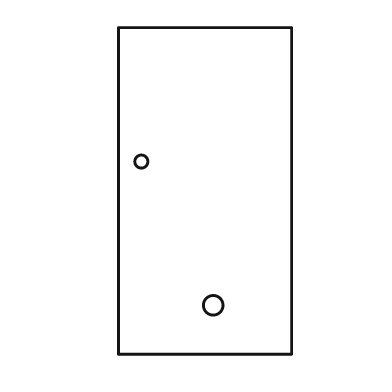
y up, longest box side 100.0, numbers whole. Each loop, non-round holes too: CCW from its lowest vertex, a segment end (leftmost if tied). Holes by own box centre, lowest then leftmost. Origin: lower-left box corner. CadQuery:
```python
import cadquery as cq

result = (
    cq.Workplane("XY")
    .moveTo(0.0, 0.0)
    .lineTo(53.0, 0.0)
    .lineTo(53.0, 100.0)
    .lineTo(0.0, 100.0)
    .close()
    .moveTo(29.0, 15.0)
    .circle(3.0)
    .moveTo(7.0, 59.0)
    .circle(2.0)
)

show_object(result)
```